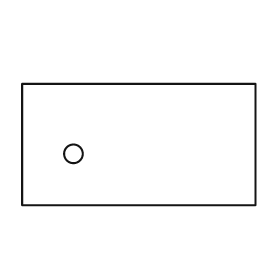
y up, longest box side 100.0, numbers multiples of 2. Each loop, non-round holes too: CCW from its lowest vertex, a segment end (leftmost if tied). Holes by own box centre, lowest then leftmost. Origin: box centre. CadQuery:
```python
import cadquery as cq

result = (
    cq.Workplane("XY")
    .moveTo(-50.0, -26.0)
    .lineTo(50.0, -26.0)
    .lineTo(50.0, 26.0)
    .lineTo(-50.0, 26.0)
    .close()
    .moveTo(-28.0, -4.0)
    .circle(4.0)
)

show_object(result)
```